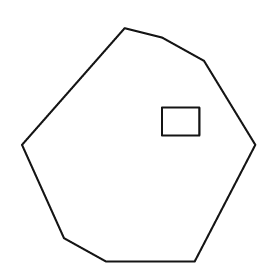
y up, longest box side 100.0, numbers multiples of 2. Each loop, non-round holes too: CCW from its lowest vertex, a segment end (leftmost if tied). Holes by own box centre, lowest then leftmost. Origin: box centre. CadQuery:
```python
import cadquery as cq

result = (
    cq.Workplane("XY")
    .moveTo(-14.0, -50.0)
    .lineTo(24.0, -50.0)
    .lineTo(50.0, 0.0)
    .lineTo(28.0, 36.0)
    .lineTo(10.0, 46.0)
    .lineTo(-6.0, 50.0)
    .lineTo(-50.0, 0.0)
    .lineTo(-32.0, -40.0)
    .close()
    .moveTo(10.0, 4.0)
    .lineTo(26.0, 4.0)
    .lineTo(26.0, 16.0)
    .lineTo(10.0, 16.0)
    .close()
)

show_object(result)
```